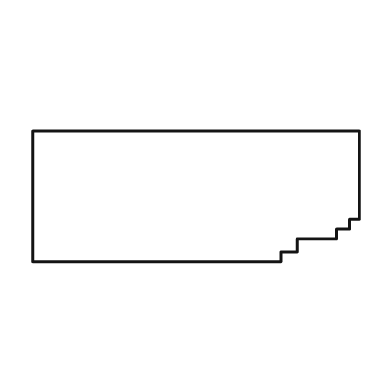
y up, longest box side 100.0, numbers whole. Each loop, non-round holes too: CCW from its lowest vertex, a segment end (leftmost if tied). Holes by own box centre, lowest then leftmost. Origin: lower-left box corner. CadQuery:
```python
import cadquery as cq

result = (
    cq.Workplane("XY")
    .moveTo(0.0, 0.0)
    .lineTo(76.0, 0.0)
    .lineTo(76.0, 3.0)
    .lineTo(81.0, 3.0)
    .lineTo(81.0, 7.0)
    .lineTo(93.0, 7.0)
    .lineTo(93.0, 10.0)
    .lineTo(97.0, 10.0)
    .lineTo(97.0, 13.0)
    .lineTo(100.0, 13.0)
    .lineTo(100.0, 40.0)
    .lineTo(0.0, 40.0)
    .close()
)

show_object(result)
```